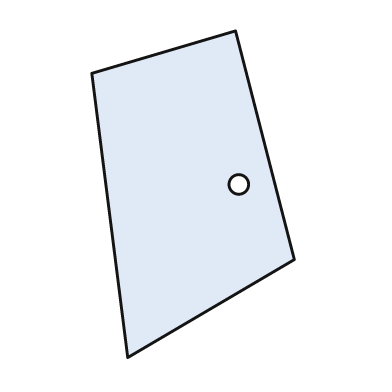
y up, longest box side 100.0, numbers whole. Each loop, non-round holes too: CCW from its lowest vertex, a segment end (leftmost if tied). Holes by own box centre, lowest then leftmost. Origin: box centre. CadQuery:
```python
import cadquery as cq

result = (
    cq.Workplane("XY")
    .moveTo(-20.0, -50.0)
    .lineTo(31.0, -20.0)
    .lineTo(13.0, 50.0)
    .lineTo(-31.0, 37.0)
    .close()
    .moveTo(14.0, 3.0)
    .circle(3.0)
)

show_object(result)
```